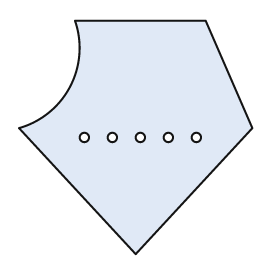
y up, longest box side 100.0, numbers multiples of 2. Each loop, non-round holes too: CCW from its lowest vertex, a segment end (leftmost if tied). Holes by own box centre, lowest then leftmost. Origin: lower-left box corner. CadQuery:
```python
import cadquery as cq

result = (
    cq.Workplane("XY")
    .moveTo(50.0, 0.0)
    .lineTo(100.0, 54.0)
    .lineTo(80.0, 100.0)
    .lineTo(24.0, 100.0)
    .threePointArc((22.0, 72.0), (0.0, 54.0))
    .close()
    .moveTo(28.0, 50.0)
    .circle(2.0)
    .moveTo(40.0, 50.0)
    .circle(2.0)
    .moveTo(52.0, 50.0)
    .circle(2.0)
    .moveTo(64.0, 50.0)
    .circle(2.0)
    .moveTo(76.0, 50.0)
    .circle(2.0)
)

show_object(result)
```